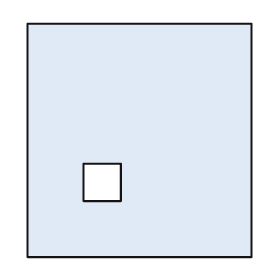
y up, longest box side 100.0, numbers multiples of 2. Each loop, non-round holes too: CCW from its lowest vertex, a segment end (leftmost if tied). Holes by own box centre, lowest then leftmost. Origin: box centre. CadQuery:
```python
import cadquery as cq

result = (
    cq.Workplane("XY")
    .moveTo(-48.0, -50.0)
    .lineTo(48.0, -50.0)
    .lineTo(48.0, 50.0)
    .lineTo(-48.0, 50.0)
    .close()
    .moveTo(-24.0, -26.0)
    .lineTo(-8.0, -26.0)
    .lineTo(-8.0, -10.0)
    .lineTo(-24.0, -10.0)
    .close()
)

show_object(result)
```